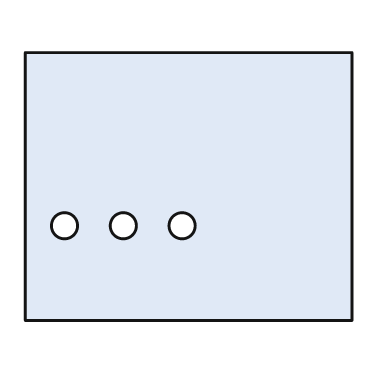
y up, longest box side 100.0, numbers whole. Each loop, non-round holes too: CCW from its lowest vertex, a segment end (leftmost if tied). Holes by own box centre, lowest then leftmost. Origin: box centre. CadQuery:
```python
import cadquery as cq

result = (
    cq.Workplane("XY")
    .moveTo(-50.0, -41.0)
    .lineTo(50.0, -41.0)
    .lineTo(50.0, 41.0)
    .lineTo(-50.0, 41.0)
    .close()
    .moveTo(-38.0, -12.0)
    .circle(4.0)
    .moveTo(-20.0, -12.0)
    .circle(4.0)
    .moveTo(-2.0, -12.0)
    .circle(4.0)
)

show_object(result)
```